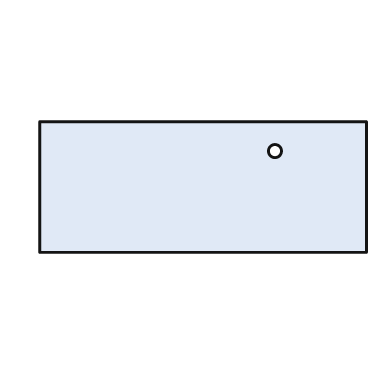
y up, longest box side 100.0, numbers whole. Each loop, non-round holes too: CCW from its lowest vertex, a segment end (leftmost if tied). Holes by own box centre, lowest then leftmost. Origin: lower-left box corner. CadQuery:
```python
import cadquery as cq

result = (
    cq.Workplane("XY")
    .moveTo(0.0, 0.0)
    .lineTo(100.0, 0.0)
    .lineTo(100.0, 40.0)
    .lineTo(0.0, 40.0)
    .close()
    .moveTo(72.0, 31.0)
    .circle(2.0)
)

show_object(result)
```